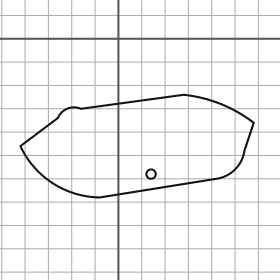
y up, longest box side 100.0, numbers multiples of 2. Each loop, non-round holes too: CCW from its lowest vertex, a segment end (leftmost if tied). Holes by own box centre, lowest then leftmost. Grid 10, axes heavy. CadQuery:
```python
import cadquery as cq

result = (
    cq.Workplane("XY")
    .moveTo(-8.0, -68.0)
    .lineTo(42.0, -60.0)
    .threePointArc((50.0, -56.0), (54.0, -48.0))
    .lineTo(58.0, -36.0)
    .threePointArc((44.0, -28.0), (28.0, -24.0))
    .lineTo(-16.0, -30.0)
    .threePointArc((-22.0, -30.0), (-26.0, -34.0))
    .lineTo(-42.0, -46.0)
    .threePointArc((-28.0, -62.0), (-8.0, -68.0))
    .close()
    .moveTo(14.0, -58.0)
    .circle(2.0)
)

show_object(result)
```